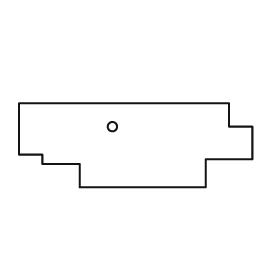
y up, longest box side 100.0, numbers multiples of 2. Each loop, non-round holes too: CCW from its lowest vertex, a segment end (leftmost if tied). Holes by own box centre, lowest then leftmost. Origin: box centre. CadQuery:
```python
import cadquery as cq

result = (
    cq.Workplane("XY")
    .moveTo(-24.0, -18.0)
    .lineTo(30.0, -18.0)
    .lineTo(30.0, -6.0)
    .lineTo(50.0, -6.0)
    .lineTo(50.0, 8.0)
    .lineTo(40.0, 8.0)
    .lineTo(40.0, 18.0)
    .lineTo(-50.0, 18.0)
    .lineTo(-50.0, -4.0)
    .lineTo(-40.0, -4.0)
    .lineTo(-40.0, -8.0)
    .lineTo(-24.0, -8.0)
    .close()
    .moveTo(-10.0, 8.0)
    .circle(2.0)
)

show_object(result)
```